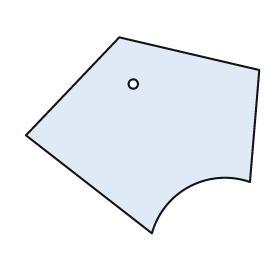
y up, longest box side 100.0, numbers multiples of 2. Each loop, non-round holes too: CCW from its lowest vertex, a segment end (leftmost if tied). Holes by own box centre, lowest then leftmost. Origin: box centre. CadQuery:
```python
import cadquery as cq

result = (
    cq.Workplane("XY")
    .moveTo(4.0, -42.0)
    .threePointArc((20.0, -22.0), (46.0, -20.0))
    .lineTo(50.0, 28.0)
    .lineTo(-10.0, 42.0)
    .lineTo(-50.0, 0.0)
    .close()
    .moveTo(-4.0, 22.0)
    .circle(2.0)
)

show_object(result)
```